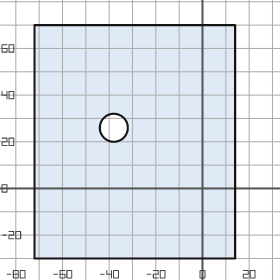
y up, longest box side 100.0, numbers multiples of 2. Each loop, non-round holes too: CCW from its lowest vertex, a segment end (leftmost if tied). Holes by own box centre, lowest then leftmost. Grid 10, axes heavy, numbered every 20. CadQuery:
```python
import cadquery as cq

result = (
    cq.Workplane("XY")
    .moveTo(-72.0, -30.0)
    .lineTo(14.0, -30.0)
    .lineTo(14.0, 70.0)
    .lineTo(-72.0, 70.0)
    .close()
    .moveTo(-38.0, 26.0)
    .circle(6.0)
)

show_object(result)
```